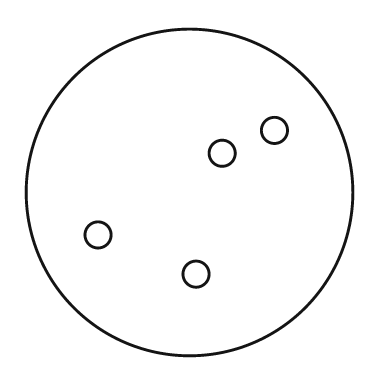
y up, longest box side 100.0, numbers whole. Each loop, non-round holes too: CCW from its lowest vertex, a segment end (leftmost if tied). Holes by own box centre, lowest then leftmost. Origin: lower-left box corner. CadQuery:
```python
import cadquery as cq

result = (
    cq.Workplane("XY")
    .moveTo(50.0, 50.0)
    .circle(50.0)
    .moveTo(52.0, 25.0)
    .circle(4.0)
    .moveTo(22.0, 37.0)
    .circle(4.0)
    .moveTo(60.0, 62.0)
    .circle(4.0)
    .moveTo(76.0, 69.0)
    .circle(4.0)
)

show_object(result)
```